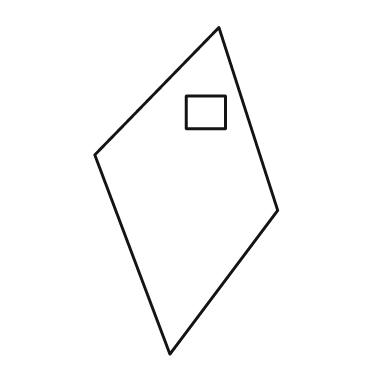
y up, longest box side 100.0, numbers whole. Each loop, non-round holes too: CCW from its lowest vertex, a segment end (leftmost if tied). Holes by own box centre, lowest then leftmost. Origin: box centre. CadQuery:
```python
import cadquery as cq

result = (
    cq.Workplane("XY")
    .moveTo(-5.0, -50.0)
    .lineTo(28.0, -6.0)
    .lineTo(10.0, 50.0)
    .lineTo(-28.0, 11.0)
    .close()
    .moveTo(0.0, 19.0)
    .lineTo(12.0, 19.0)
    .lineTo(12.0, 29.0)
    .lineTo(0.0, 29.0)
    .close()
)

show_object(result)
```